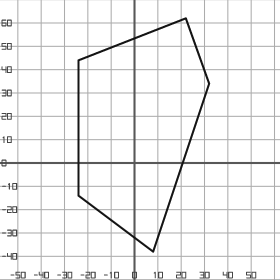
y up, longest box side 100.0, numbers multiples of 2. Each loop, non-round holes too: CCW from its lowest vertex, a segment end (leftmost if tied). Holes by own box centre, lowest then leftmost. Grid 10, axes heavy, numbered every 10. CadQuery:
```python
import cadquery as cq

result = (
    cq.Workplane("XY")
    .moveTo(8.0, -38.0)
    .lineTo(32.0, 34.0)
    .lineTo(22.0, 62.0)
    .lineTo(-24.0, 44.0)
    .lineTo(-24.0, -14.0)
    .close()
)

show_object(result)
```